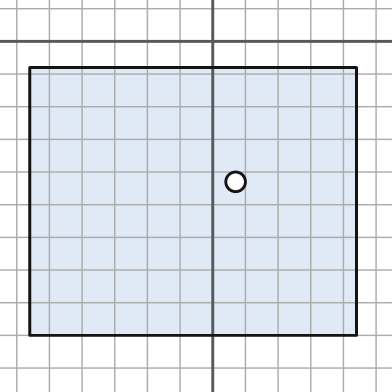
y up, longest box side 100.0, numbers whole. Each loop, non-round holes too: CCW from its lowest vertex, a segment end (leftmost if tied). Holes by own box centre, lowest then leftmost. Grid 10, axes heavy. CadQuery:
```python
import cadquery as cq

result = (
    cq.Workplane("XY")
    .moveTo(-56.0, -90.0)
    .lineTo(44.0, -90.0)
    .lineTo(44.0, -8.0)
    .lineTo(-56.0, -8.0)
    .close()
    .moveTo(7.0, -43.0)
    .circle(3.0)
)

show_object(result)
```